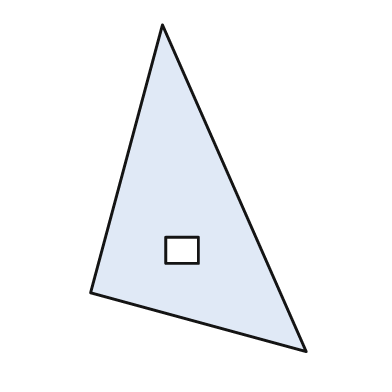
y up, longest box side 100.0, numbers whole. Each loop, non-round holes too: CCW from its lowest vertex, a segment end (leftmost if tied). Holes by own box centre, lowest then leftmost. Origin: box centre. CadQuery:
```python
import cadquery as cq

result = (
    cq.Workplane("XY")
    .moveTo(33.0, -50.0)
    .lineTo(-11.0, 50.0)
    .lineTo(-33.0, -32.0)
    .close()
    .moveTo(-10.0, -23.0)
    .lineTo(0.0, -23.0)
    .lineTo(0.0, -15.0)
    .lineTo(-10.0, -15.0)
    .close()
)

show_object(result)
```